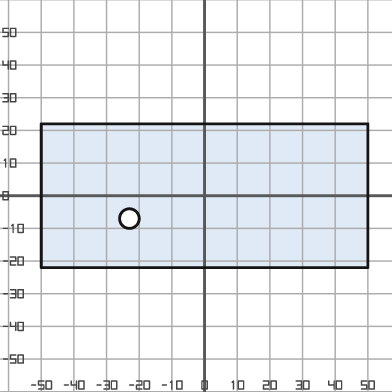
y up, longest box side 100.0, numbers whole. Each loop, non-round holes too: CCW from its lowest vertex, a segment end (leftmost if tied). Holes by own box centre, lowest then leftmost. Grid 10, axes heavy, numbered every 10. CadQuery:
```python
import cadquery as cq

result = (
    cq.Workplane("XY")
    .moveTo(-50.0, -22.0)
    .lineTo(50.0, -22.0)
    .lineTo(50.0, 22.0)
    .lineTo(-50.0, 22.0)
    .close()
    .moveTo(-23.0, -7.0)
    .circle(3.0)
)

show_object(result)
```